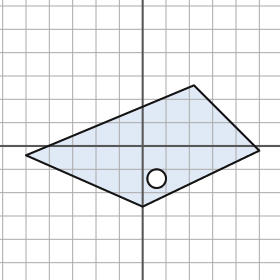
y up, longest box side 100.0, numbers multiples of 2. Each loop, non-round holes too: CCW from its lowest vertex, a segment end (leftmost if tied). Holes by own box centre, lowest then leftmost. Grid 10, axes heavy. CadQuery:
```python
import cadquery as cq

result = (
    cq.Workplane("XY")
    .moveTo(0.0, -26.0)
    .lineTo(50.0, -2.0)
    .lineTo(22.0, 26.0)
    .lineTo(-50.0, -4.0)
    .close()
    .moveTo(6.0, -14.0)
    .circle(4.0)
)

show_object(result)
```